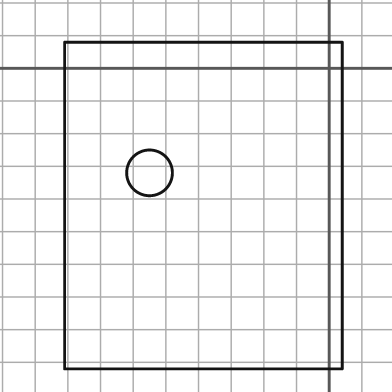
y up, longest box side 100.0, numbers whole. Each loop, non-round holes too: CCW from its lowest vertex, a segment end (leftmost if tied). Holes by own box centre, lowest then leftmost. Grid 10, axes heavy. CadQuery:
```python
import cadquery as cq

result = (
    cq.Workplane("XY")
    .moveTo(-81.0, -92.0)
    .lineTo(4.0, -92.0)
    .lineTo(4.0, 8.0)
    .lineTo(-81.0, 8.0)
    .close()
    .moveTo(-55.0, -32.0)
    .circle(7.0)
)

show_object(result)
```